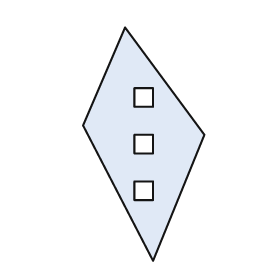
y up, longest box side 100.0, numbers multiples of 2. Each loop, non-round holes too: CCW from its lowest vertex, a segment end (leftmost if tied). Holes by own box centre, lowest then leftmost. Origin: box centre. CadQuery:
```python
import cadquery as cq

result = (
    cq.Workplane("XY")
    .moveTo(4.0, -50.0)
    .lineTo(26.0, 4.0)
    .lineTo(-8.0, 50.0)
    .lineTo(-26.0, 8.0)
    .close()
    .moveTo(-4.0, -24.0)
    .lineTo(4.0, -24.0)
    .lineTo(4.0, -16.0)
    .lineTo(-4.0, -16.0)
    .close()
    .moveTo(-4.0, -4.0)
    .lineTo(4.0, -4.0)
    .lineTo(4.0, 4.0)
    .lineTo(-4.0, 4.0)
    .close()
    .moveTo(-4.0, 16.0)
    .lineTo(4.0, 16.0)
    .lineTo(4.0, 24.0)
    .lineTo(-4.0, 24.0)
    .close()
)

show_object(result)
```